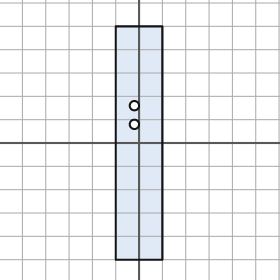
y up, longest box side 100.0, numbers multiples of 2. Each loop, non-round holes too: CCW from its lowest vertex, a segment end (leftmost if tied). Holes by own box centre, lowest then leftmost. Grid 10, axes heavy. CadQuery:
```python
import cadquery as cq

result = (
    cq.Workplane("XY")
    .moveTo(-10.0, -50.0)
    .lineTo(10.0, -50.0)
    .lineTo(10.0, 50.0)
    .lineTo(-10.0, 50.0)
    .close()
    .moveTo(-2.0, 8.0)
    .circle(2.0)
    .moveTo(-2.0, 16.0)
    .circle(2.0)
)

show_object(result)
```